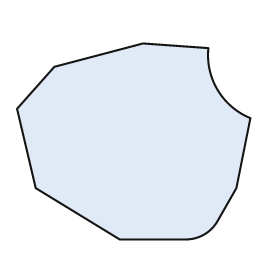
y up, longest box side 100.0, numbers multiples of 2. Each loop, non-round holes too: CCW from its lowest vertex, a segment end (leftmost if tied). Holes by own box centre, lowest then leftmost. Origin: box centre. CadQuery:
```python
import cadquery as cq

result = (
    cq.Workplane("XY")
    .moveTo(-6.0, -42.0)
    .lineTo(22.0, -42.0)
    .threePointArc((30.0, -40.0), (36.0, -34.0))
    .lineTo(44.0, -20.0)
    .lineTo(50.0, 10.0)
    .threePointArc((36.0, 22.0), (32.0, 40.0))
    .lineTo(4.0, 42.0)
    .lineTo(-34.0, 32.0)
    .lineTo(-50.0, 14.0)
    .lineTo(-42.0, -20.0)
    .close()
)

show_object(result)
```